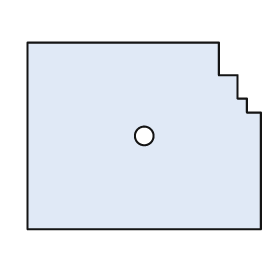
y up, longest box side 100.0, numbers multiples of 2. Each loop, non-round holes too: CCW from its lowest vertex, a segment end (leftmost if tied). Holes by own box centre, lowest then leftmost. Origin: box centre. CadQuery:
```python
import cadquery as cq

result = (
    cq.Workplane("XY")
    .moveTo(-50.0, -40.0)
    .lineTo(50.0, -40.0)
    .lineTo(50.0, 10.0)
    .lineTo(44.0, 10.0)
    .lineTo(44.0, 16.0)
    .lineTo(40.0, 16.0)
    .lineTo(40.0, 26.0)
    .lineTo(32.0, 26.0)
    .lineTo(32.0, 40.0)
    .lineTo(-50.0, 40.0)
    .close()
    .moveTo(0.0, 0.0)
    .circle(4.0)
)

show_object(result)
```